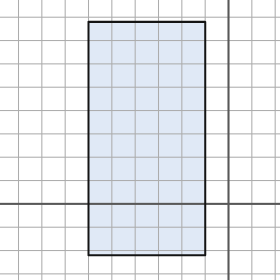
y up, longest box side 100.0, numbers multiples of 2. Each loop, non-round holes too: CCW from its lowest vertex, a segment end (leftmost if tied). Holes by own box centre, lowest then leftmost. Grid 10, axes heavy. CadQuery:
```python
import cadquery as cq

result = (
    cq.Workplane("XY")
    .moveTo(-60.0, -22.0)
    .lineTo(-10.0, -22.0)
    .lineTo(-10.0, 78.0)
    .lineTo(-60.0, 78.0)
    .close()
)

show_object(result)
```